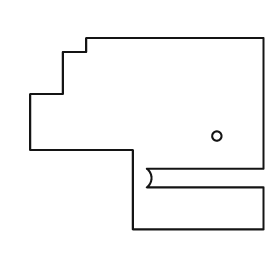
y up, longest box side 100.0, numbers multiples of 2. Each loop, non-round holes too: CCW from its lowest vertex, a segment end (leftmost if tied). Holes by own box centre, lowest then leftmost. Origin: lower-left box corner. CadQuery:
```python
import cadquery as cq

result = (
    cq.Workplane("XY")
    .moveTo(44.0, 0.0)
    .lineTo(100.0, 0.0)
    .lineTo(100.0, 18.0)
    .lineTo(50.0, 18.0)
    .threePointArc((52.0, 22.0), (50.0, 26.0))
    .lineTo(100.0, 26.0)
    .lineTo(100.0, 82.0)
    .lineTo(24.0, 82.0)
    .lineTo(24.0, 76.0)
    .lineTo(14.0, 76.0)
    .lineTo(14.0, 58.0)
    .lineTo(0.0, 58.0)
    .lineTo(0.0, 34.0)
    .lineTo(44.0, 34.0)
    .close()
    .moveTo(80.0, 40.0)
    .circle(2.0)
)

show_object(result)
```